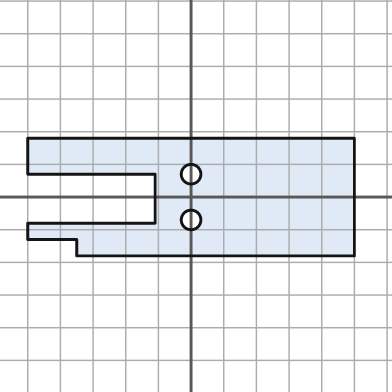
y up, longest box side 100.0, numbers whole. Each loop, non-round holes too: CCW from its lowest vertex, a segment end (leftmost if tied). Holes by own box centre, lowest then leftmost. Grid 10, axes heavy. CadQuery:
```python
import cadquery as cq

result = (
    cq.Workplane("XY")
    .moveTo(-35.0, -18.0)
    .lineTo(50.0, -18.0)
    .lineTo(50.0, 18.0)
    .lineTo(-50.0, 18.0)
    .lineTo(-50.0, 7.0)
    .lineTo(-11.0, 7.0)
    .lineTo(-11.0, -8.0)
    .lineTo(-50.0, -8.0)
    .lineTo(-50.0, -13.0)
    .lineTo(-35.0, -13.0)
    .close()
    .moveTo(0.0, -7.0)
    .circle(3.0)
    .moveTo(0.0, 7.0)
    .circle(3.0)
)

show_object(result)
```